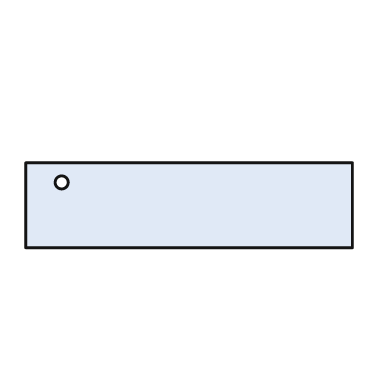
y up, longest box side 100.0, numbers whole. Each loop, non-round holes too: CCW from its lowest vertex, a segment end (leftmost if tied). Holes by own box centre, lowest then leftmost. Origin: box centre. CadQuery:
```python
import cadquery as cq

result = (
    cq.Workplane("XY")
    .moveTo(-50.0, -13.0)
    .lineTo(50.0, -13.0)
    .lineTo(50.0, 13.0)
    .lineTo(-50.0, 13.0)
    .close()
    .moveTo(-39.0, 7.0)
    .circle(2.0)
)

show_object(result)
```